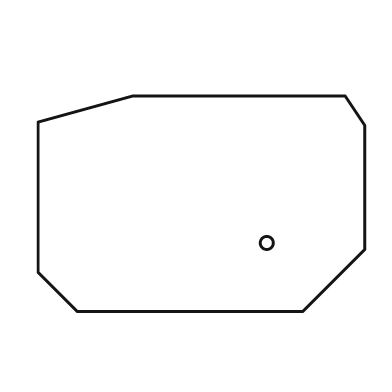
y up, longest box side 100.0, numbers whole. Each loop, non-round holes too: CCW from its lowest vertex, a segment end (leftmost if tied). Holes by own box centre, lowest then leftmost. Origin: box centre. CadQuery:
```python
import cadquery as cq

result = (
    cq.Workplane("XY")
    .moveTo(-38.0, -33.0)
    .lineTo(31.0, -33.0)
    .lineTo(50.0, -14.0)
    .lineTo(50.0, 24.0)
    .lineTo(44.0, 33.0)
    .lineTo(-21.0, 33.0)
    .lineTo(-50.0, 25.0)
    .lineTo(-50.0, -21.0)
    .close()
    .moveTo(20.0, -12.0)
    .circle(2.0)
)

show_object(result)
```